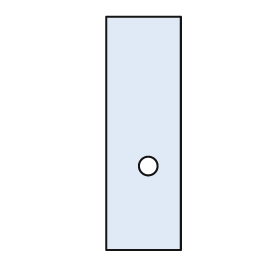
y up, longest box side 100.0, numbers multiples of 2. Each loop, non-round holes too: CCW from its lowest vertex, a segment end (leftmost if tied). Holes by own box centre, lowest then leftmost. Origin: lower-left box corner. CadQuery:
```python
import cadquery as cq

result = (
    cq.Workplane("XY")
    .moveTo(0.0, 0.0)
    .lineTo(32.0, 0.0)
    .lineTo(32.0, 100.0)
    .lineTo(0.0, 100.0)
    .close()
    .moveTo(18.0, 36.0)
    .circle(4.0)
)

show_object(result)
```